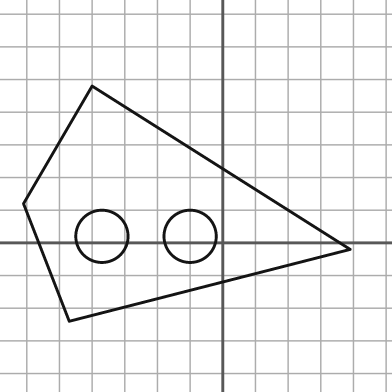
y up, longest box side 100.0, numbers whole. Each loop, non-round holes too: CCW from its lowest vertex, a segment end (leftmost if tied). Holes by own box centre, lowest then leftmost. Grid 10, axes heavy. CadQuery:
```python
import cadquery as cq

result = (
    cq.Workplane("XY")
    .moveTo(-47.0, -24.0)
    .lineTo(39.0, -2.0)
    .lineTo(-40.0, 48.0)
    .lineTo(-61.0, 12.0)
    .close()
    .moveTo(-37.0, 2.0)
    .circle(8.0)
    .moveTo(-10.0, 2.0)
    .circle(8.0)
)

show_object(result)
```